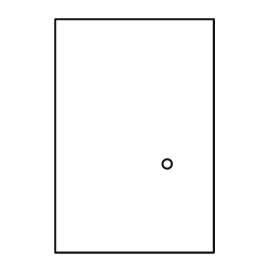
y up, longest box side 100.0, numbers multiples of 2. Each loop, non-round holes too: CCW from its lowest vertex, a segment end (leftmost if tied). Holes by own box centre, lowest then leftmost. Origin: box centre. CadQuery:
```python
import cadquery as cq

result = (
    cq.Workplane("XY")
    .moveTo(-34.0, -50.0)
    .lineTo(34.0, -50.0)
    .lineTo(34.0, 50.0)
    .lineTo(-34.0, 50.0)
    .close()
    .moveTo(14.0, -12.0)
    .circle(2.0)
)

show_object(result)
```